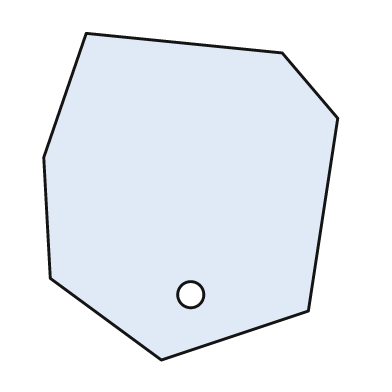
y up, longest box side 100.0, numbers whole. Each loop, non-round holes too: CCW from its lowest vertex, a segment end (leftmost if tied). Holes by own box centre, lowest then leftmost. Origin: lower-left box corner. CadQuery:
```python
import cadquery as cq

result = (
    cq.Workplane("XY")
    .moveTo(36.0, 0.0)
    .lineTo(81.0, 15.0)
    .lineTo(90.0, 74.0)
    .lineTo(73.0, 94.0)
    .lineTo(13.0, 100.0)
    .lineTo(0.0, 62.0)
    .lineTo(2.0, 25.0)
    .close()
    .moveTo(45.0, 20.0)
    .circle(4.0)
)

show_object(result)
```